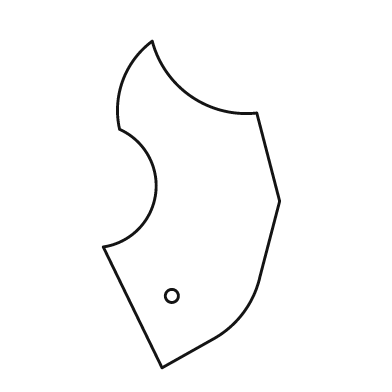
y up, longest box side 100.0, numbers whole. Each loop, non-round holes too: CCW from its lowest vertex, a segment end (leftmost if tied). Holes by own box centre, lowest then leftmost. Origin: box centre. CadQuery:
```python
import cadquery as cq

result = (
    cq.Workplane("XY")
    .moveTo(-9.0, -50.0)
    .lineTo(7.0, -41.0)
    .threePointArc((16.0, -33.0), (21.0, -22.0))
    .lineTo(27.0, 1.0)
    .lineTo(20.0, 28.0)
    .threePointArc((0.0, 33.0), (-12.0, 50.0))
    .threePointArc((-21.0, 38.0), (-22.0, 23.0))
    .threePointArc((-11.0, 3.0), (-27.0, -13.0))
    .close()
    .moveTo(-6.0, -28.0)
    .circle(2.0)
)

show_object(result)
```